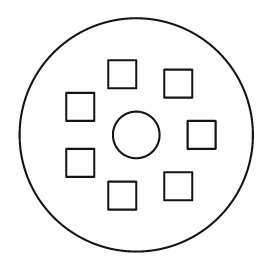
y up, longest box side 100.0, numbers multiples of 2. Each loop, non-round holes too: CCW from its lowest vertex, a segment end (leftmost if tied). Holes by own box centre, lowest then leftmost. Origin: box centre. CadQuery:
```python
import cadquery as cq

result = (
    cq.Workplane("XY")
    .moveTo(0.0, 0.0)
    .circle(50.0)
    .moveTo(-12.0, -32.0)
    .lineTo(0.0, -32.0)
    .lineTo(0.0, -20.0)
    .lineTo(-12.0, -20.0)
    .close()
    .moveTo(12.0, -28.0)
    .lineTo(24.0, -28.0)
    .lineTo(24.0, -16.0)
    .lineTo(12.0, -16.0)
    .close()
    .moveTo(-30.0, -18.0)
    .lineTo(-18.0, -18.0)
    .lineTo(-18.0, -6.0)
    .lineTo(-30.0, -6.0)
    .close()
    .moveTo(0.0, 0.0)
    .circle(10.0)
    .moveTo(22.0, -6.0)
    .lineTo(34.0, -6.0)
    .lineTo(34.0, 6.0)
    .lineTo(22.0, 6.0)
    .close()
    .moveTo(-30.0, 6.0)
    .lineTo(-18.0, 6.0)
    .lineTo(-18.0, 18.0)
    .lineTo(-30.0, 18.0)
    .close()
    .moveTo(12.0, 16.0)
    .lineTo(24.0, 16.0)
    .lineTo(24.0, 28.0)
    .lineTo(12.0, 28.0)
    .close()
    .moveTo(-12.0, 20.0)
    .lineTo(0.0, 20.0)
    .lineTo(0.0, 32.0)
    .lineTo(-12.0, 32.0)
    .close()
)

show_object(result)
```